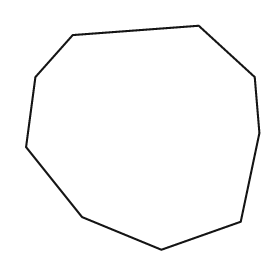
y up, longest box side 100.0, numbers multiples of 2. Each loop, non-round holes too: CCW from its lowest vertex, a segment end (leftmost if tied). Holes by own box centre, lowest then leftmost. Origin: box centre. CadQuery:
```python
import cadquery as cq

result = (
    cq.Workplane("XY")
    .moveTo(8.0, -48.0)
    .lineTo(42.0, -36.0)
    .lineTo(50.0, 2.0)
    .lineTo(48.0, 26.0)
    .lineTo(24.0, 48.0)
    .lineTo(-30.0, 44.0)
    .lineTo(-46.0, 26.0)
    .lineTo(-50.0, -4.0)
    .lineTo(-26.0, -34.0)
    .close()
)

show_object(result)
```